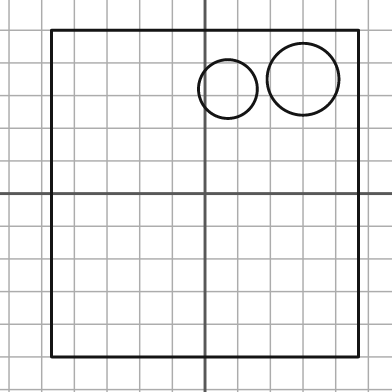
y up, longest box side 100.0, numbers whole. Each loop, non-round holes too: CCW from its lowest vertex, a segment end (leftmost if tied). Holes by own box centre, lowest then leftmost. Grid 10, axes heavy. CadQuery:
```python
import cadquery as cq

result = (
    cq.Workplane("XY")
    .moveTo(-47.0, -50.0)
    .lineTo(47.0, -50.0)
    .lineTo(47.0, 50.0)
    .lineTo(-47.0, 50.0)
    .close()
    .moveTo(7.0, 32.0)
    .circle(9.0)
    .moveTo(30.0, 35.0)
    .circle(11.0)
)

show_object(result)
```